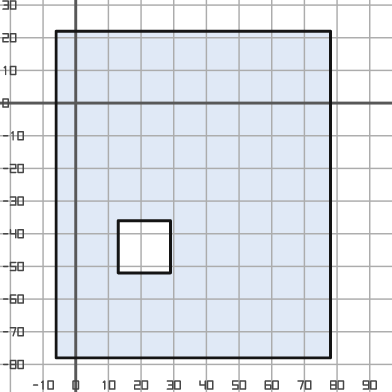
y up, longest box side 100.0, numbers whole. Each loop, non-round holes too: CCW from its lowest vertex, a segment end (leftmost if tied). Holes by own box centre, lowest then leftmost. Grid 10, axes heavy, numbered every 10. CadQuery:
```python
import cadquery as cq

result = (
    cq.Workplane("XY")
    .moveTo(-6.0, -78.0)
    .lineTo(78.0, -78.0)
    .lineTo(78.0, 22.0)
    .lineTo(-6.0, 22.0)
    .close()
    .moveTo(13.0, -52.0)
    .lineTo(29.0, -52.0)
    .lineTo(29.0, -36.0)
    .lineTo(13.0, -36.0)
    .close()
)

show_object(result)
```